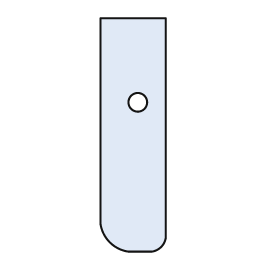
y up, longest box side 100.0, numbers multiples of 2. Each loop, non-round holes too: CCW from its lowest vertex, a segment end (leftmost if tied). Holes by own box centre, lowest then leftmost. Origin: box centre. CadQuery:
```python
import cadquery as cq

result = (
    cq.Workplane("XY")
    .moveTo(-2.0, -50.0)
    .lineTo(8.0, -50.0)
    .threePointArc((12.0, -48.0), (14.0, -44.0))
    .lineTo(14.0, 50.0)
    .lineTo(-14.0, 50.0)
    .lineTo(-14.0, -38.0)
    .threePointArc((-10.0, -46.0), (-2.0, -50.0))
    .close()
    .moveTo(2.0, 14.0)
    .circle(4.0)
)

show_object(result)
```